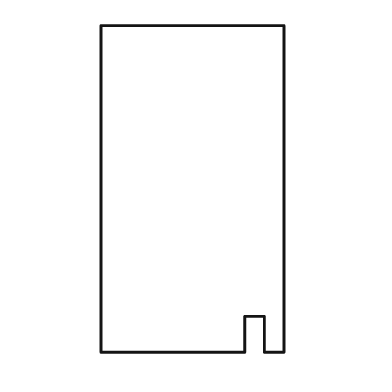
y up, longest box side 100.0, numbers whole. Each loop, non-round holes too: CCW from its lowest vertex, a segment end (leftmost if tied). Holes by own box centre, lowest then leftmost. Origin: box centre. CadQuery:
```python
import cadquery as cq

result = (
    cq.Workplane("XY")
    .moveTo(-28.0, -50.0)
    .lineTo(16.0, -50.0)
    .lineTo(16.0, -39.0)
    .lineTo(22.0, -39.0)
    .lineTo(22.0, -50.0)
    .lineTo(28.0, -50.0)
    .lineTo(28.0, 50.0)
    .lineTo(-28.0, 50.0)
    .close()
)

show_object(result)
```